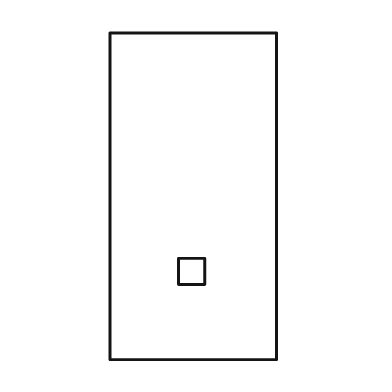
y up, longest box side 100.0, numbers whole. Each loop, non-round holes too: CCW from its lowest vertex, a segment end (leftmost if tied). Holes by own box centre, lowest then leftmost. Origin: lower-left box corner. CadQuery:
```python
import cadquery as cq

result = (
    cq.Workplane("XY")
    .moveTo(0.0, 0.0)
    .lineTo(51.0, 0.0)
    .lineTo(51.0, 100.0)
    .lineTo(0.0, 100.0)
    .close()
    .moveTo(21.0, 23.0)
    .lineTo(29.0, 23.0)
    .lineTo(29.0, 31.0)
    .lineTo(21.0, 31.0)
    .close()
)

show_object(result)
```